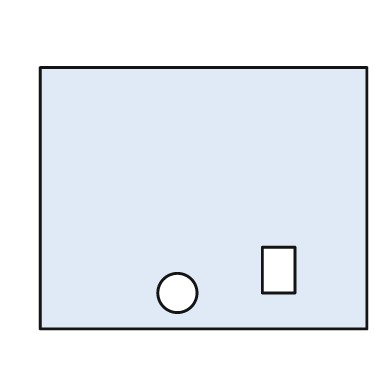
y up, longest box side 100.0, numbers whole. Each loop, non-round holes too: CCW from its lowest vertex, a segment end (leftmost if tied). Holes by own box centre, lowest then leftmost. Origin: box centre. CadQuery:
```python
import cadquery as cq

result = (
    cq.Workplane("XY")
    .moveTo(-50.0, -40.0)
    .lineTo(50.0, -40.0)
    .lineTo(50.0, 40.0)
    .lineTo(-50.0, 40.0)
    .close()
    .moveTo(-8.0, -29.0)
    .circle(6.0)
    .moveTo(18.0, -29.0)
    .lineTo(28.0, -29.0)
    .lineTo(28.0, -15.0)
    .lineTo(18.0, -15.0)
    .close()
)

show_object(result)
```